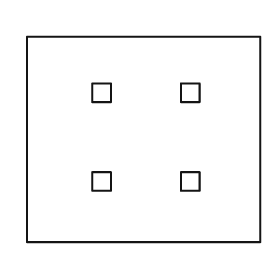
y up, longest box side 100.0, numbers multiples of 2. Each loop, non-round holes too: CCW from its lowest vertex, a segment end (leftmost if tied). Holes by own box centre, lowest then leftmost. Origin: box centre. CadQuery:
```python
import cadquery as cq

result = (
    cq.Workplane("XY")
    .moveTo(-50.0, -44.0)
    .lineTo(50.0, -44.0)
    .lineTo(50.0, 44.0)
    .lineTo(-50.0, 44.0)
    .close()
    .moveTo(-22.0, -22.0)
    .lineTo(-14.0, -22.0)
    .lineTo(-14.0, -14.0)
    .lineTo(-22.0, -14.0)
    .close()
    .moveTo(16.0, -22.0)
    .lineTo(24.0, -22.0)
    .lineTo(24.0, -14.0)
    .lineTo(16.0, -14.0)
    .close()
    .moveTo(-22.0, 16.0)
    .lineTo(-14.0, 16.0)
    .lineTo(-14.0, 24.0)
    .lineTo(-22.0, 24.0)
    .close()
    .moveTo(16.0, 16.0)
    .lineTo(24.0, 16.0)
    .lineTo(24.0, 24.0)
    .lineTo(16.0, 24.0)
    .close()
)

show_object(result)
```